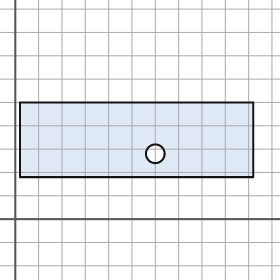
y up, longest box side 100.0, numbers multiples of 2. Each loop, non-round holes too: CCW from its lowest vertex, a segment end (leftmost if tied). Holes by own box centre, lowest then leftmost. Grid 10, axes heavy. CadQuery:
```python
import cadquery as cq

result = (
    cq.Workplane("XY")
    .moveTo(2.0, 18.0)
    .lineTo(102.0, 18.0)
    .lineTo(102.0, 50.0)
    .lineTo(2.0, 50.0)
    .close()
    .moveTo(60.0, 28.0)
    .circle(4.0)
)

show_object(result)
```